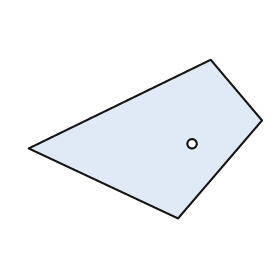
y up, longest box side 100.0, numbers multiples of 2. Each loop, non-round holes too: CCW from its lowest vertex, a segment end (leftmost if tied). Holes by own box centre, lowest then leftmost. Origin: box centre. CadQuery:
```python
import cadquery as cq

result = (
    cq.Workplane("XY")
    .moveTo(14.0, -34.0)
    .lineTo(50.0, 8.0)
    .lineTo(28.0, 34.0)
    .lineTo(-50.0, -4.0)
    .close()
    .moveTo(20.0, -2.0)
    .circle(2.0)
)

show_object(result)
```